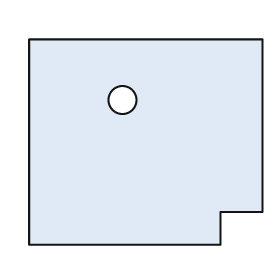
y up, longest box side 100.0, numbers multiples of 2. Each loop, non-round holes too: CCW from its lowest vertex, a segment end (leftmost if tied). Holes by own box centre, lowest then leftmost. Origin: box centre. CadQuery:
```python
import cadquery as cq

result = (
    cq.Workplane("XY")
    .moveTo(-50.0, -44.0)
    .lineTo(32.0, -44.0)
    .lineTo(32.0, -30.0)
    .lineTo(50.0, -30.0)
    .lineTo(50.0, 44.0)
    .lineTo(-50.0, 44.0)
    .close()
    .moveTo(-10.0, 18.0)
    .circle(6.0)
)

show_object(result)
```